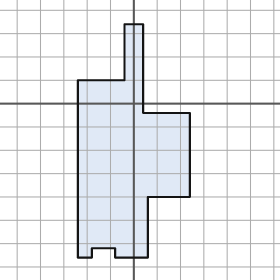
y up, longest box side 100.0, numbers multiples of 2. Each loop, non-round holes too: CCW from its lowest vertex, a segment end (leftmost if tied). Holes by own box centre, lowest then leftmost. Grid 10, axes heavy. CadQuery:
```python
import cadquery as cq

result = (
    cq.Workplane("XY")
    .moveTo(-24.0, -66.0)
    .lineTo(-18.0, -66.0)
    .lineTo(-18.0, -62.0)
    .lineTo(-8.0, -62.0)
    .lineTo(-8.0, -66.0)
    .lineTo(6.0, -66.0)
    .lineTo(6.0, -40.0)
    .lineTo(24.0, -40.0)
    .lineTo(24.0, -4.0)
    .lineTo(4.0, -4.0)
    .lineTo(4.0, 34.0)
    .lineTo(-4.0, 34.0)
    .lineTo(-4.0, 10.0)
    .lineTo(-24.0, 10.0)
    .close()
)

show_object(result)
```